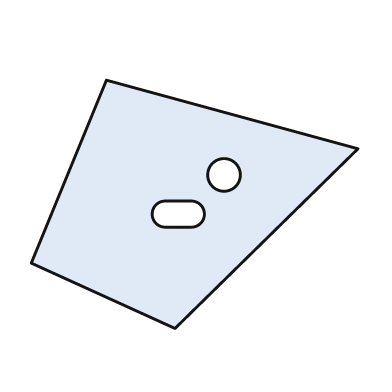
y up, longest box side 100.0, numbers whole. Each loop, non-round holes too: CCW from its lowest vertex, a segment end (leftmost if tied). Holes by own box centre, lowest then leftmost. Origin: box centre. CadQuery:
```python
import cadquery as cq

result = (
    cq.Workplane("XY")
    .moveTo(-6.0, -38.0)
    .lineTo(50.0, 17.0)
    .lineTo(-27.0, 38.0)
    .lineTo(-50.0, -18.0)
    .close()
    .moveTo(-9.0, -7.0)
    .lineTo(-1.0, -7.0)
    .threePointArc((3.0, -3.0), (-1.0, 1.0))
    .lineTo(-9.0, 1.0)
    .threePointArc((-13.0, -3.0), (-9.0, -7.0))
    .close()
    .moveTo(9.0, 9.0)
    .circle(5.0)
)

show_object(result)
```